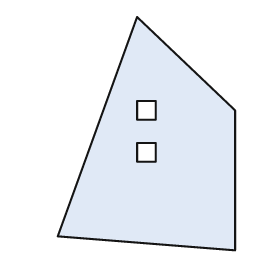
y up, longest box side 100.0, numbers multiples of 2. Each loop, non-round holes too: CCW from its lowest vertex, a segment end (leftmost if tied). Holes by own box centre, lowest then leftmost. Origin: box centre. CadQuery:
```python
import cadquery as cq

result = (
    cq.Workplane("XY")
    .moveTo(38.0, -50.0)
    .lineTo(38.0, 10.0)
    .lineTo(-4.0, 50.0)
    .lineTo(-38.0, -44.0)
    .close()
    .moveTo(-4.0, -12.0)
    .lineTo(4.0, -12.0)
    .lineTo(4.0, -4.0)
    .lineTo(-4.0, -4.0)
    .close()
    .moveTo(-4.0, 6.0)
    .lineTo(4.0, 6.0)
    .lineTo(4.0, 14.0)
    .lineTo(-4.0, 14.0)
    .close()
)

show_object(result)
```